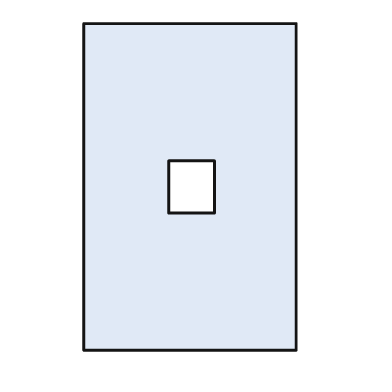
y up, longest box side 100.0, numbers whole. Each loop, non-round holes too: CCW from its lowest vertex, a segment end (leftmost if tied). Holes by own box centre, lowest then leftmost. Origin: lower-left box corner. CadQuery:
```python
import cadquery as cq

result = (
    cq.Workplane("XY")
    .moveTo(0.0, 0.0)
    .lineTo(65.0, 0.0)
    .lineTo(65.0, 100.0)
    .lineTo(0.0, 100.0)
    .close()
    .moveTo(26.0, 42.0)
    .lineTo(40.0, 42.0)
    .lineTo(40.0, 58.0)
    .lineTo(26.0, 58.0)
    .close()
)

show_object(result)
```